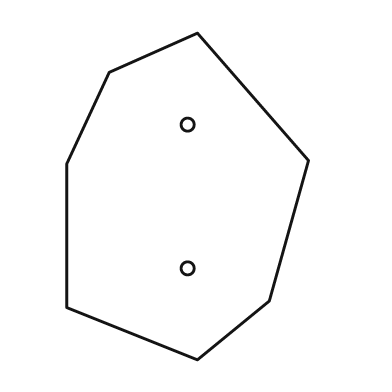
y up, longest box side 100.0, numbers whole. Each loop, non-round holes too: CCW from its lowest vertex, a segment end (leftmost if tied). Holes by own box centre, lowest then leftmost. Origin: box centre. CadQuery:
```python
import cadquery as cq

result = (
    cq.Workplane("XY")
    .moveTo(3.0, -50.0)
    .lineTo(25.0, -32.0)
    .lineTo(37.0, 11.0)
    .lineTo(3.0, 50.0)
    .lineTo(-24.0, 38.0)
    .lineTo(-37.0, 10.0)
    .lineTo(-37.0, -34.0)
    .close()
    .moveTo(0.0, -22.0)
    .circle(2.0)
    .moveTo(0.0, 22.0)
    .circle(2.0)
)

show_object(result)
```